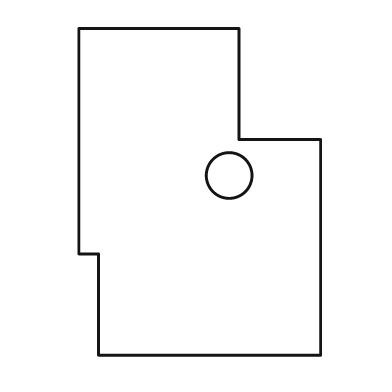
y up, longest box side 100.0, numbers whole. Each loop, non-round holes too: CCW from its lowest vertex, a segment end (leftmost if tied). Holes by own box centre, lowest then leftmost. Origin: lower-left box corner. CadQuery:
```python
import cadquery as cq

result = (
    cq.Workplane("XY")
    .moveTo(6.0, 0.0)
    .lineTo(74.0, 0.0)
    .lineTo(74.0, 66.0)
    .lineTo(49.0, 66.0)
    .lineTo(49.0, 100.0)
    .lineTo(0.0, 100.0)
    .lineTo(0.0, 31.0)
    .lineTo(6.0, 31.0)
    .close()
    .moveTo(46.0, 55.0)
    .circle(7.0)
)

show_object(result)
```